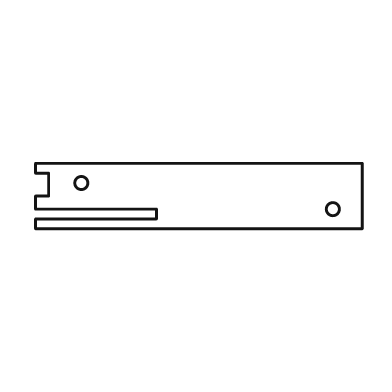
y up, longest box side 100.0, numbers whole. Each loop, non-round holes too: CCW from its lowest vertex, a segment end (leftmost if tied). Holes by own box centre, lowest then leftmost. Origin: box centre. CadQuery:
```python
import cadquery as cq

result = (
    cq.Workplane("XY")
    .moveTo(-50.0, -10.0)
    .lineTo(50.0, -10.0)
    .lineTo(50.0, 10.0)
    .lineTo(-50.0, 10.0)
    .lineTo(-50.0, 7.0)
    .lineTo(-46.0, 7.0)
    .lineTo(-46.0, 0.0)
    .lineTo(-50.0, 0.0)
    .lineTo(-50.0, -4.0)
    .lineTo(-13.0, -4.0)
    .lineTo(-13.0, -7.0)
    .lineTo(-50.0, -7.0)
    .close()
    .moveTo(41.0, -4.0)
    .circle(2.0)
    .moveTo(-36.0, 4.0)
    .circle(2.0)
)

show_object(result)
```